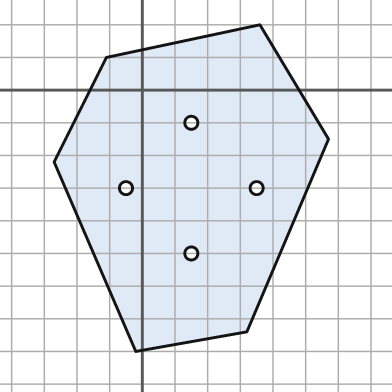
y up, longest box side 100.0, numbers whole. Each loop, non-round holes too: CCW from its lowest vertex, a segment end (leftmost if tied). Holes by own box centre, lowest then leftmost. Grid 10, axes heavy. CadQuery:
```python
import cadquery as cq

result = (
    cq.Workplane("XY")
    .moveTo(-2.0, -80.0)
    .lineTo(32.0, -74.0)
    .lineTo(57.0, -15.0)
    .lineTo(36.0, 20.0)
    .lineTo(-11.0, 10.0)
    .lineTo(-27.0, -22.0)
    .close()
    .moveTo(15.0, -50.0)
    .circle(2.0)
    .moveTo(-5.0, -30.0)
    .circle(2.0)
    .moveTo(35.0, -30.0)
    .circle(2.0)
    .moveTo(15.0, -10.0)
    .circle(2.0)
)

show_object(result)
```